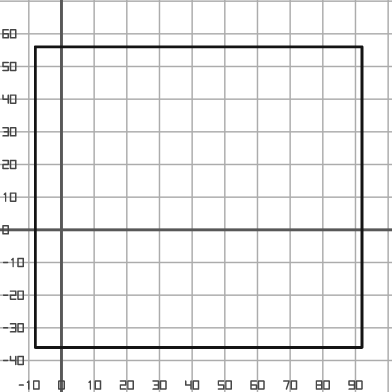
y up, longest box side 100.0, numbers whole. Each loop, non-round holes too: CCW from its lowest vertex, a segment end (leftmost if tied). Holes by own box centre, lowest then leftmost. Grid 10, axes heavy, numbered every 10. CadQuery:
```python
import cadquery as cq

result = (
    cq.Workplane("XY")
    .moveTo(-8.0, -36.0)
    .lineTo(92.0, -36.0)
    .lineTo(92.0, 56.0)
    .lineTo(-8.0, 56.0)
    .close()
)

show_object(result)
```